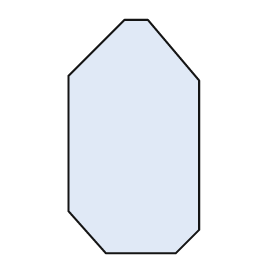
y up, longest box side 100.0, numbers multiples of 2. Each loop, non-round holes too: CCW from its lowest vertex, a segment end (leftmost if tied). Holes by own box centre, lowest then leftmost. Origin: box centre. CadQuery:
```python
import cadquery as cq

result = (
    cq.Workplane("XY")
    .moveTo(-12.0, -50.0)
    .lineTo(18.0, -50.0)
    .lineTo(28.0, -40.0)
    .lineTo(28.0, 24.0)
    .lineTo(6.0, 50.0)
    .lineTo(-4.0, 50.0)
    .lineTo(-28.0, 26.0)
    .lineTo(-28.0, -32.0)
    .close()
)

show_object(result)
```